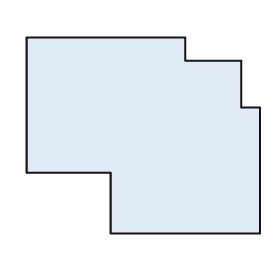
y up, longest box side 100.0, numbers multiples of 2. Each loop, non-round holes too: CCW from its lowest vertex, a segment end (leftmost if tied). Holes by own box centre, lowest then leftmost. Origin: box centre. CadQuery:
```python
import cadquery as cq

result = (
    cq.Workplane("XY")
    .moveTo(-14.0, -42.0)
    .lineTo(50.0, -42.0)
    .lineTo(50.0, 12.0)
    .lineTo(42.0, 12.0)
    .lineTo(42.0, 32.0)
    .lineTo(18.0, 32.0)
    .lineTo(18.0, 42.0)
    .lineTo(-50.0, 42.0)
    .lineTo(-50.0, -16.0)
    .lineTo(-14.0, -16.0)
    .close()
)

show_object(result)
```